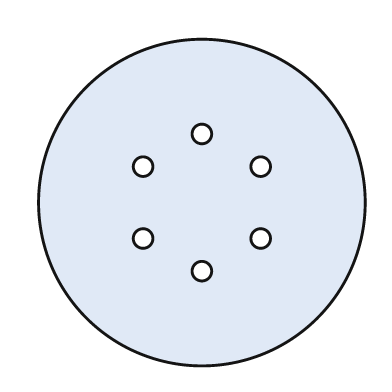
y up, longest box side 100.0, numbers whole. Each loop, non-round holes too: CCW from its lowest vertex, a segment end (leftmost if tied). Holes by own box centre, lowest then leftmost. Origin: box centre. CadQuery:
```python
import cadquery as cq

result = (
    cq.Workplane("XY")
    .moveTo(0.0, 0.0)
    .circle(50.0)
    .moveTo(0.0, -21.0)
    .circle(3.0)
    .moveTo(-18.0, -11.0)
    .circle(3.0)
    .moveTo(18.0, -11.0)
    .circle(3.0)
    .moveTo(-18.0, 11.0)
    .circle(3.0)
    .moveTo(18.0, 11.0)
    .circle(3.0)
    .moveTo(0.0, 21.0)
    .circle(3.0)
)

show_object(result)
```